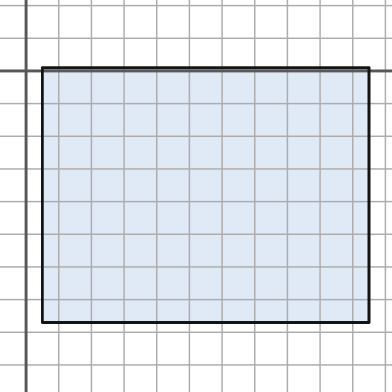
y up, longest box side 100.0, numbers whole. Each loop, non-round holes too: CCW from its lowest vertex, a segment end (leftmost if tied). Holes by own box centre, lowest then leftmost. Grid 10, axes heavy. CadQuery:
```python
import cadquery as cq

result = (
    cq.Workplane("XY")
    .moveTo(5.0, -77.0)
    .lineTo(105.0, -77.0)
    .lineTo(105.0, 1.0)
    .lineTo(5.0, 1.0)
    .close()
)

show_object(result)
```